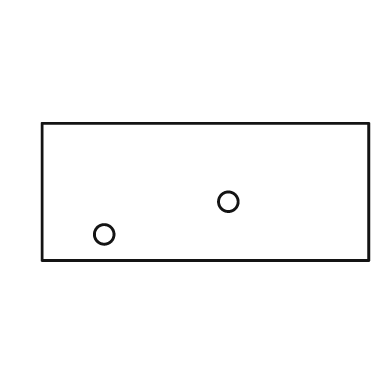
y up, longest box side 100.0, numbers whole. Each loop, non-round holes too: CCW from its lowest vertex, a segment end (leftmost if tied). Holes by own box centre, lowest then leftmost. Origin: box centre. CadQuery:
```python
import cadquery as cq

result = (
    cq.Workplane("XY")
    .moveTo(-50.0, -21.0)
    .lineTo(50.0, -21.0)
    .lineTo(50.0, 21.0)
    .lineTo(-50.0, 21.0)
    .close()
    .moveTo(-31.0, -13.0)
    .circle(3.0)
    .moveTo(7.0, -3.0)
    .circle(3.0)
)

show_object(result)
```